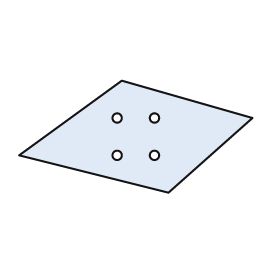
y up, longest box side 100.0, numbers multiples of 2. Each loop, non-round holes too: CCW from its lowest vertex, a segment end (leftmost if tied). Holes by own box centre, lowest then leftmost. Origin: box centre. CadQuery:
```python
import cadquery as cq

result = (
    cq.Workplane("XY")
    .moveTo(14.0, -24.0)
    .lineTo(50.0, 8.0)
    .lineTo(-6.0, 24.0)
    .lineTo(-50.0, -8.0)
    .close()
    .moveTo(-8.0, -8.0)
    .circle(2.0)
    .moveTo(8.0, -8.0)
    .circle(2.0)
    .moveTo(-8.0, 8.0)
    .circle(2.0)
    .moveTo(8.0, 8.0)
    .circle(2.0)
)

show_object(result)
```